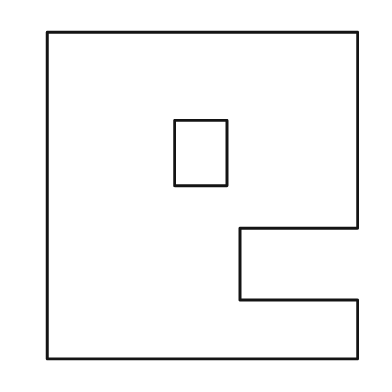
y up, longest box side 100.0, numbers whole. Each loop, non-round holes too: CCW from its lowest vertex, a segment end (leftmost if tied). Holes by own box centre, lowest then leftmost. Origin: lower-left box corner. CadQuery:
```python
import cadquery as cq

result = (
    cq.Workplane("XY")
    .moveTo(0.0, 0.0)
    .lineTo(95.0, 0.0)
    .lineTo(95.0, 18.0)
    .lineTo(59.0, 18.0)
    .lineTo(59.0, 40.0)
    .lineTo(95.0, 40.0)
    .lineTo(95.0, 100.0)
    .lineTo(0.0, 100.0)
    .close()
    .moveTo(39.0, 53.0)
    .lineTo(55.0, 53.0)
    .lineTo(55.0, 73.0)
    .lineTo(39.0, 73.0)
    .close()
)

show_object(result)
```